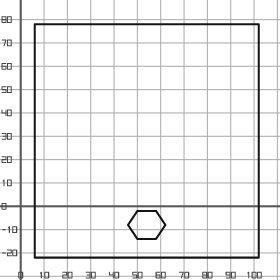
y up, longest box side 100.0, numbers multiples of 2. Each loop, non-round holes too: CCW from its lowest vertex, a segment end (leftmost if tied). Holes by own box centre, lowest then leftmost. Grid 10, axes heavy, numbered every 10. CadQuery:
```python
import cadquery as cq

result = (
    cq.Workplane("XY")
    .moveTo(6.0, -22.0)
    .lineTo(102.0, -22.0)
    .lineTo(102.0, 78.0)
    .lineTo(6.0, 78.0)
    .close()
    .moveTo(50.0, -14.0)
    .lineTo(58.0, -14.0)
    .lineTo(62.0, -8.0)
    .lineTo(58.0, -2.0)
    .lineTo(50.0, -2.0)
    .lineTo(46.0, -8.0)
    .close()
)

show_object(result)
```